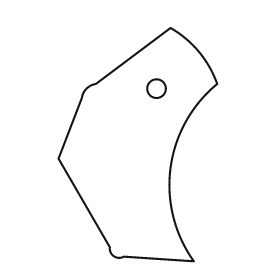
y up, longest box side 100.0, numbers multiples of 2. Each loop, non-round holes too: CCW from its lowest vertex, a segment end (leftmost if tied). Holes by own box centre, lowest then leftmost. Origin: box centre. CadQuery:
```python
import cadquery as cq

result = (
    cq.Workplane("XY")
    .moveTo(24.0, -50.0)
    .threePointArc((14.0, -10.0), (34.0, 26.0))
    .threePointArc((26.0, 40.0), (14.0, 50.0))
    .lineTo(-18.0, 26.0)
    .threePointArc((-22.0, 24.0), (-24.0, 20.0))
    .lineTo(-34.0, -6.0)
    .lineTo(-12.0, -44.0)
    .threePointArc((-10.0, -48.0), (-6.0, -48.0))
    .close()
    .moveTo(8.0, 24.0)
    .circle(4.0)
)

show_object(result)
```